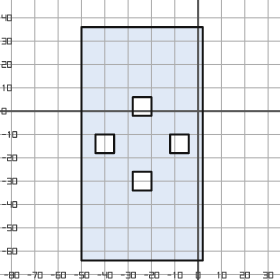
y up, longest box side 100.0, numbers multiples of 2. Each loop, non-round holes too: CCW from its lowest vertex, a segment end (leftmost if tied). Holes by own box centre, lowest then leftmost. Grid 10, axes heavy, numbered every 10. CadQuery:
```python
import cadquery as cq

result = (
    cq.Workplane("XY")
    .moveTo(-50.0, -64.0)
    .lineTo(2.0, -64.0)
    .lineTo(2.0, 36.0)
    .lineTo(-50.0, 36.0)
    .close()
    .moveTo(-28.0, -34.0)
    .lineTo(-20.0, -34.0)
    .lineTo(-20.0, -26.0)
    .lineTo(-28.0, -26.0)
    .close()
    .moveTo(-44.0, -18.0)
    .lineTo(-36.0, -18.0)
    .lineTo(-36.0, -10.0)
    .lineTo(-44.0, -10.0)
    .close()
    .moveTo(-12.0, -18.0)
    .lineTo(-4.0, -18.0)
    .lineTo(-4.0, -10.0)
    .lineTo(-12.0, -10.0)
    .close()
    .moveTo(-28.0, -2.0)
    .lineTo(-20.0, -2.0)
    .lineTo(-20.0, 6.0)
    .lineTo(-28.0, 6.0)
    .close()
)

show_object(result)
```